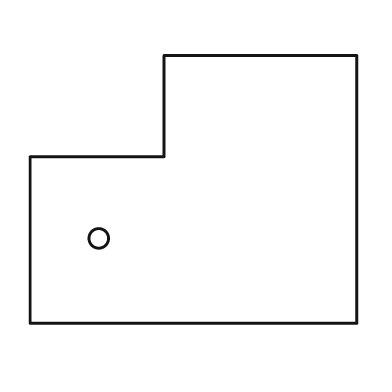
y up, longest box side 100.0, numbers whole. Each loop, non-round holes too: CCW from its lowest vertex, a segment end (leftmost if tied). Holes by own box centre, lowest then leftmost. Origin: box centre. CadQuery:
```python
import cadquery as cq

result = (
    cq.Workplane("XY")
    .moveTo(-50.0, -41.0)
    .lineTo(50.0, -41.0)
    .lineTo(50.0, 41.0)
    .lineTo(-9.0, 41.0)
    .lineTo(-9.0, 10.0)
    .lineTo(-50.0, 10.0)
    .close()
    .moveTo(-29.0, -15.0)
    .circle(3.0)
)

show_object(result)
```